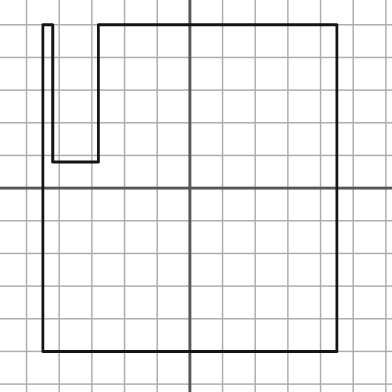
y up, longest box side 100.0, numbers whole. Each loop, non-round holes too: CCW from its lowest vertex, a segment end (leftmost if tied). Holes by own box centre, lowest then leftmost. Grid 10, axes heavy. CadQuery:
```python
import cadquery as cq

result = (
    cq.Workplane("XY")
    .moveTo(-45.0, -50.0)
    .lineTo(45.0, -50.0)
    .lineTo(45.0, 50.0)
    .lineTo(-28.0, 50.0)
    .lineTo(-28.0, 8.0)
    .lineTo(-42.0, 8.0)
    .lineTo(-42.0, 50.0)
    .lineTo(-45.0, 50.0)
    .close()
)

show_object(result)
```